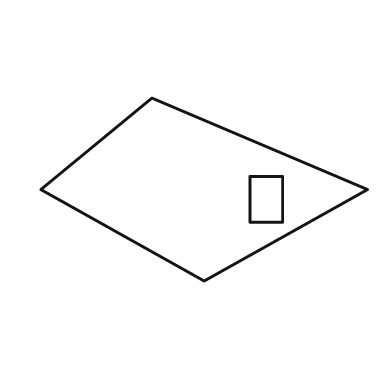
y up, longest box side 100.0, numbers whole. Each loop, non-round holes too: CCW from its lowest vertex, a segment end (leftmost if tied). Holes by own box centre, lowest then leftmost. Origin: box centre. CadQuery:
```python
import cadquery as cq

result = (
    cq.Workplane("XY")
    .moveTo(0.0, -28.0)
    .lineTo(50.0, 0.0)
    .lineTo(-16.0, 28.0)
    .lineTo(-50.0, 0.0)
    .close()
    .moveTo(14.0, -10.0)
    .lineTo(24.0, -10.0)
    .lineTo(24.0, 4.0)
    .lineTo(14.0, 4.0)
    .close()
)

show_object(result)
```